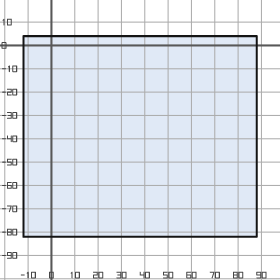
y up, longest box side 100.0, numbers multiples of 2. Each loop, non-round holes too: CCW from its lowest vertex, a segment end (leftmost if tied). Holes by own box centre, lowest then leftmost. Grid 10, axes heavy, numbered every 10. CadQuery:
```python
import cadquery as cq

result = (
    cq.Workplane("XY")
    .moveTo(-12.0, -82.0)
    .lineTo(88.0, -82.0)
    .lineTo(88.0, 4.0)
    .lineTo(-12.0, 4.0)
    .close()
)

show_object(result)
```